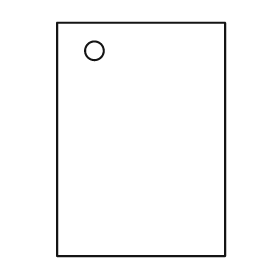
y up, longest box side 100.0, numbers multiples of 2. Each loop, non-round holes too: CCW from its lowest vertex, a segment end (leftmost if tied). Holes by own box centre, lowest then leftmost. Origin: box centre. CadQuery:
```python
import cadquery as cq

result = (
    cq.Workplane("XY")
    .moveTo(-36.0, -50.0)
    .lineTo(36.0, -50.0)
    .lineTo(36.0, 50.0)
    .lineTo(-36.0, 50.0)
    .close()
    .moveTo(-20.0, 38.0)
    .circle(4.0)
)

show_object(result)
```